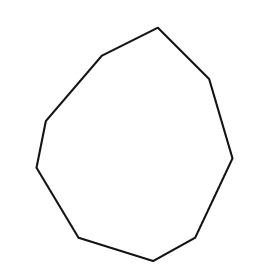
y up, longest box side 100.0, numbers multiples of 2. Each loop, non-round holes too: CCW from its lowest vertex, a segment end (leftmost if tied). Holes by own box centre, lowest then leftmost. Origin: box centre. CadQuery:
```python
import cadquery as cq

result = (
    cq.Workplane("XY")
    .moveTo(8.0, -50.0)
    .lineTo(26.0, -40.0)
    .lineTo(42.0, -6.0)
    .lineTo(32.0, 28.0)
    .lineTo(10.0, 50.0)
    .lineTo(-14.0, 38.0)
    .lineTo(-38.0, 10.0)
    .lineTo(-42.0, -10.0)
    .lineTo(-24.0, -40.0)
    .close()
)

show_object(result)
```